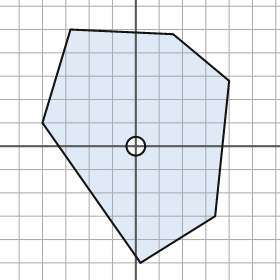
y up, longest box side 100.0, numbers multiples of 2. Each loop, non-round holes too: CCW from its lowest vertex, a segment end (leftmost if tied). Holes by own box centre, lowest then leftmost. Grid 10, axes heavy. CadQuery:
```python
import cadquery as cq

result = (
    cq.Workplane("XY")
    .moveTo(2.0, -50.0)
    .lineTo(34.0, -30.0)
    .lineTo(40.0, 28.0)
    .lineTo(16.0, 48.0)
    .lineTo(-28.0, 50.0)
    .lineTo(-40.0, 10.0)
    .close()
    .moveTo(0.0, 0.0)
    .circle(4.0)
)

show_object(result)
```